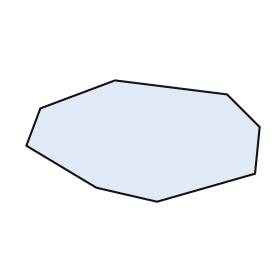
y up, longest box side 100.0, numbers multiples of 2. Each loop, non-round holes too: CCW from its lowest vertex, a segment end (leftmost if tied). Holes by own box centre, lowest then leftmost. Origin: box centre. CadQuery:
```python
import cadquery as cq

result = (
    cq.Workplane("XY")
    .moveTo(6.0, -26.0)
    .lineTo(48.0, -14.0)
    .lineTo(50.0, 6.0)
    .lineTo(36.0, 20.0)
    .lineTo(-12.0, 26.0)
    .lineTo(-44.0, 14.0)
    .lineTo(-50.0, -2.0)
    .lineTo(-20.0, -20.0)
    .close()
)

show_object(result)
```